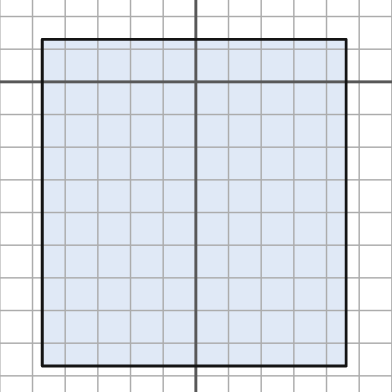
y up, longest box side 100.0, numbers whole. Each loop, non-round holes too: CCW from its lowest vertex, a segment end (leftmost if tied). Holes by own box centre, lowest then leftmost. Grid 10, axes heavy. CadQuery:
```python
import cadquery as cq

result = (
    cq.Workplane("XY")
    .moveTo(-47.0, -87.0)
    .lineTo(46.0, -87.0)
    .lineTo(46.0, 13.0)
    .lineTo(-47.0, 13.0)
    .close()
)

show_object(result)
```